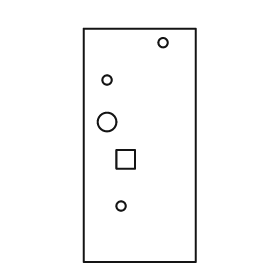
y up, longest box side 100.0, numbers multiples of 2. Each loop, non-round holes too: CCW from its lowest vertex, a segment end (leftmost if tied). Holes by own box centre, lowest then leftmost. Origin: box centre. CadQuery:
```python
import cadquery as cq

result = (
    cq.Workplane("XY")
    .moveTo(-24.0, -50.0)
    .lineTo(24.0, -50.0)
    .lineTo(24.0, 50.0)
    .lineTo(-24.0, 50.0)
    .close()
    .moveTo(-8.0, -26.0)
    .circle(2.0)
    .moveTo(-10.0, -10.0)
    .lineTo(-2.0, -10.0)
    .lineTo(-2.0, -2.0)
    .lineTo(-10.0, -2.0)
    .close()
    .moveTo(-14.0, 10.0)
    .circle(4.0)
    .moveTo(-14.0, 28.0)
    .circle(2.0)
    .moveTo(10.0, 44.0)
    .circle(2.0)
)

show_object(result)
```